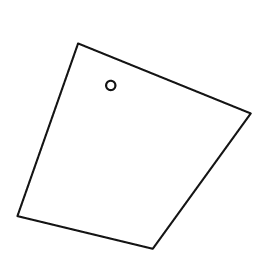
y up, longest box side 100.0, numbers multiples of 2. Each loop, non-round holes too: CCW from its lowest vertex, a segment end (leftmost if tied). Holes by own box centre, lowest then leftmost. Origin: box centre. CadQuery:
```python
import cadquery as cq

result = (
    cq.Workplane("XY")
    .moveTo(8.0, -44.0)
    .lineTo(50.0, 14.0)
    .lineTo(-24.0, 44.0)
    .lineTo(-50.0, -30.0)
    .close()
    .moveTo(-10.0, 26.0)
    .circle(2.0)
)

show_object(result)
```